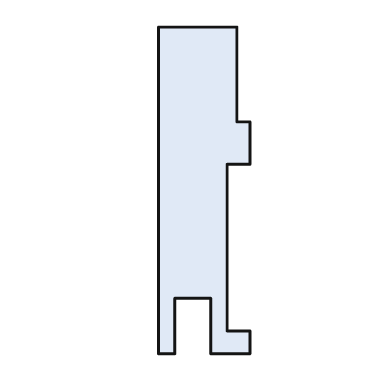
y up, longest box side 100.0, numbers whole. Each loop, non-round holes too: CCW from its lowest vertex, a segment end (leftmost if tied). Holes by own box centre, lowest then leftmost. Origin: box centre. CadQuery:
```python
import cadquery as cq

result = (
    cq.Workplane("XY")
    .moveTo(-14.0, -50.0)
    .lineTo(-9.0, -50.0)
    .lineTo(-9.0, -33.0)
    .lineTo(2.0, -33.0)
    .lineTo(2.0, -50.0)
    .lineTo(14.0, -50.0)
    .lineTo(14.0, -43.0)
    .lineTo(7.0, -43.0)
    .lineTo(7.0, 8.0)
    .lineTo(14.0, 8.0)
    .lineTo(14.0, 21.0)
    .lineTo(10.0, 21.0)
    .lineTo(10.0, 50.0)
    .lineTo(-14.0, 50.0)
    .close()
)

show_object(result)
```